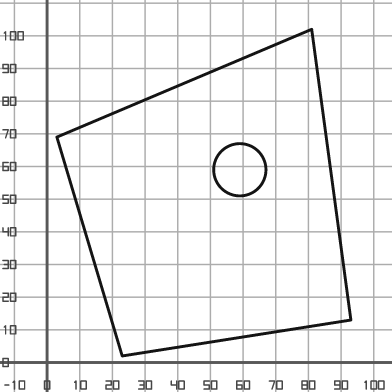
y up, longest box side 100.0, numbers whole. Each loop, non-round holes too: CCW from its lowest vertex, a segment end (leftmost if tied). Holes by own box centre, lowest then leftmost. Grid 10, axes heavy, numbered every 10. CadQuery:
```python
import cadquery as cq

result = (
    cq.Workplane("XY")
    .moveTo(23.0, 2.0)
    .lineTo(93.0, 13.0)
    .lineTo(81.0, 102.0)
    .lineTo(3.0, 69.0)
    .close()
    .moveTo(59.0, 59.0)
    .circle(8.0)
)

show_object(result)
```